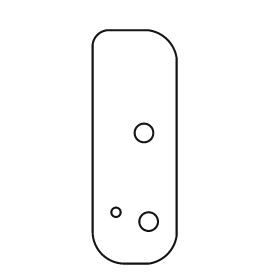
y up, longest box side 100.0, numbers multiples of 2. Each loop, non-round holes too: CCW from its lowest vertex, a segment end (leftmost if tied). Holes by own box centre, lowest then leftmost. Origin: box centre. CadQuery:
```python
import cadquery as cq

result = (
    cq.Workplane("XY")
    .moveTo(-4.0, -50.0)
    .lineTo(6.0, -50.0)
    .threePointArc((14.0, -46.0), (18.0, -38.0))
    .lineTo(18.0, 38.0)
    .threePointArc((14.0, 46.0), (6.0, 50.0))
    .lineTo(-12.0, 50.0)
    .threePointArc((-16.0, 48.0), (-18.0, 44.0))
    .lineTo(-18.0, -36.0)
    .threePointArc((-14.0, -46.0), (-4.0, -50.0))
    .close()
    .moveTo(6.0, -32.0)
    .circle(4.0)
    .moveTo(-8.0, -28.0)
    .circle(2.0)
    .moveTo(4.0, 6.0)
    .circle(4.0)
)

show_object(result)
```